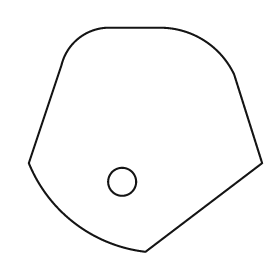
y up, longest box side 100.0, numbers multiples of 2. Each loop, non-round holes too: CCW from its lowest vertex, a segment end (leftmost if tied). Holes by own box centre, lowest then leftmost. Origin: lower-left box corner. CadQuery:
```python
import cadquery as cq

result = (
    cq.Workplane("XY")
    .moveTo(50.0, 0.0)
    .lineTo(100.0, 38.0)
    .lineTo(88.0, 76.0)
    .threePointArc((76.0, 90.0), (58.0, 96.0))
    .lineTo(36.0, 96.0)
    .threePointArc((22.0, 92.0), (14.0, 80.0))
    .lineTo(0.0, 38.0)
    .threePointArc((20.0, 12.0), (50.0, 0.0))
    .close()
    .moveTo(40.0, 30.0)
    .circle(6.0)
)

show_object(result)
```